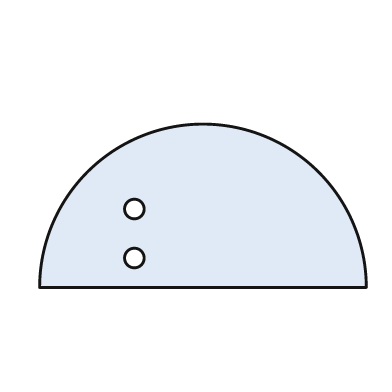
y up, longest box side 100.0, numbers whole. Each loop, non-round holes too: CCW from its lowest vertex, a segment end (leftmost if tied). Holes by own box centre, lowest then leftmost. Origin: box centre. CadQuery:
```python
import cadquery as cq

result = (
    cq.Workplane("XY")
    .moveTo(-50.0, -25.0)
    .lineTo(50.0, -25.0)
    .threePointArc((0.0, 25.0), (-50.0, -25.0))
    .close()
    .moveTo(-21.0, -16.0)
    .circle(3.0)
    .moveTo(-21.0, -1.0)
    .circle(3.0)
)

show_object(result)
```